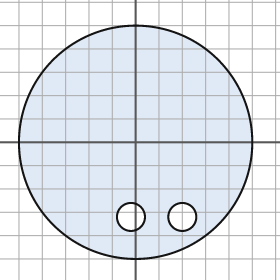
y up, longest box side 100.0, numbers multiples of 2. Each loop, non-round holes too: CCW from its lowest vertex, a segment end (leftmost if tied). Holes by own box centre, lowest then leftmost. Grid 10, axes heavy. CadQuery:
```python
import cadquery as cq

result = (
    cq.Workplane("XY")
    .moveTo(0.0, 0.0)
    .circle(50.0)
    .moveTo(-2.0, -32.0)
    .circle(6.0)
    .moveTo(20.0, -32.0)
    .circle(6.0)
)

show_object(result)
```